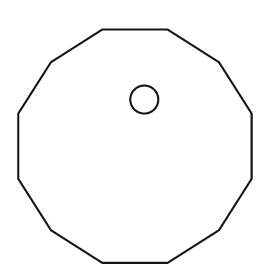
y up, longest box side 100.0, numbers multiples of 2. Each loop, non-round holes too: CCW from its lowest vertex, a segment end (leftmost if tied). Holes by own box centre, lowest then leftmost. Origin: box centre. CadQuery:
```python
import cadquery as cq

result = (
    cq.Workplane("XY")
    .moveTo(-14.0, -50.0)
    .lineTo(14.0, -50.0)
    .lineTo(36.0, -36.0)
    .lineTo(50.0, -14.0)
    .lineTo(50.0, 14.0)
    .lineTo(36.0, 36.0)
    .lineTo(14.0, 50.0)
    .lineTo(-14.0, 50.0)
    .lineTo(-36.0, 36.0)
    .lineTo(-50.0, 14.0)
    .lineTo(-50.0, -14.0)
    .lineTo(-36.0, -36.0)
    .close()
    .moveTo(4.0, 20.0)
    .circle(6.0)
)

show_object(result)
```